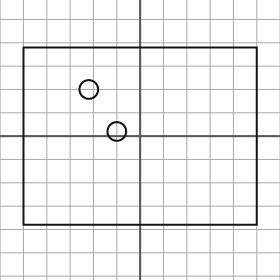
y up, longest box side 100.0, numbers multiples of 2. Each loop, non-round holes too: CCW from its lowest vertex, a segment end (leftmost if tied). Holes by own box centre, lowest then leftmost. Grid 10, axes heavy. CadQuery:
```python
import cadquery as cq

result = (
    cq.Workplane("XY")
    .moveTo(-50.0, -38.0)
    .lineTo(50.0, -38.0)
    .lineTo(50.0, 38.0)
    .lineTo(-50.0, 38.0)
    .close()
    .moveTo(-10.0, 2.0)
    .circle(4.0)
    .moveTo(-22.0, 20.0)
    .circle(4.0)
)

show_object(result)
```